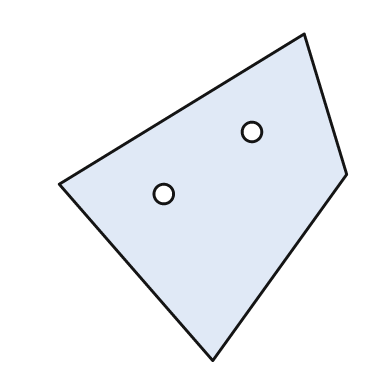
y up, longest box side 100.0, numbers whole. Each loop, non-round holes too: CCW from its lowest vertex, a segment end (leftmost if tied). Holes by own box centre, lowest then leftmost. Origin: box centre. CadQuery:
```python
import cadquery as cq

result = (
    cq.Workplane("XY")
    .moveTo(3.0, -50.0)
    .lineTo(44.0, 7.0)
    .lineTo(31.0, 50.0)
    .lineTo(-44.0, 4.0)
    .close()
    .moveTo(-12.0, 1.0)
    .circle(3.0)
    .moveTo(15.0, 20.0)
    .circle(3.0)
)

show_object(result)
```